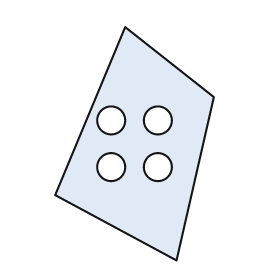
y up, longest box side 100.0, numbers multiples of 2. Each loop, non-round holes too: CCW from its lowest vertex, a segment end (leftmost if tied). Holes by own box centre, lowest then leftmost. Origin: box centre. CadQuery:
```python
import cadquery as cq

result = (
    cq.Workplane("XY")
    .moveTo(18.0, -50.0)
    .lineTo(34.0, 20.0)
    .lineTo(-4.0, 50.0)
    .lineTo(-34.0, -22.0)
    .close()
    .moveTo(-10.0, -10.0)
    .circle(6.0)
    .moveTo(10.0, -10.0)
    .circle(6.0)
    .moveTo(-10.0, 10.0)
    .circle(6.0)
    .moveTo(10.0, 10.0)
    .circle(6.0)
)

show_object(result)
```